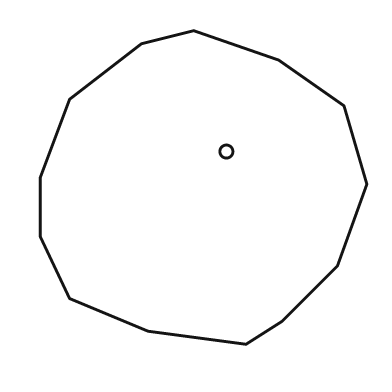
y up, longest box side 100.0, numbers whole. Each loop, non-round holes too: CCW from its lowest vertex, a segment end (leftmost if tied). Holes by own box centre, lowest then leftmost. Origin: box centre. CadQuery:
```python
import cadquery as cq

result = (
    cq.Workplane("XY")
    .moveTo(13.0, -48.0)
    .lineTo(24.0, -41.0)
    .lineTo(41.0, -24.0)
    .lineTo(50.0, 1.0)
    .lineTo(43.0, 25.0)
    .lineTo(23.0, 39.0)
    .lineTo(-3.0, 48.0)
    .lineTo(-19.0, 44.0)
    .lineTo(-41.0, 27.0)
    .lineTo(-50.0, 3.0)
    .lineTo(-50.0, -15.0)
    .lineTo(-41.0, -34.0)
    .lineTo(-17.0, -44.0)
    .close()
    .moveTo(7.0, 11.0)
    .circle(2.0)
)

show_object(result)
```